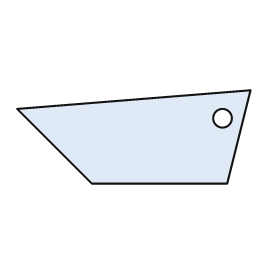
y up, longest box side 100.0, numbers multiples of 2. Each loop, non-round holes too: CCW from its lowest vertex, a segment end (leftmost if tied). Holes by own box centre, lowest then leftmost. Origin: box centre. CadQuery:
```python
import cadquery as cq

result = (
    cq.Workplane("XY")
    .moveTo(-18.0, -20.0)
    .lineTo(40.0, -20.0)
    .lineTo(50.0, 20.0)
    .lineTo(-50.0, 12.0)
    .close()
    .moveTo(38.0, 8.0)
    .circle(4.0)
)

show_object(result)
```